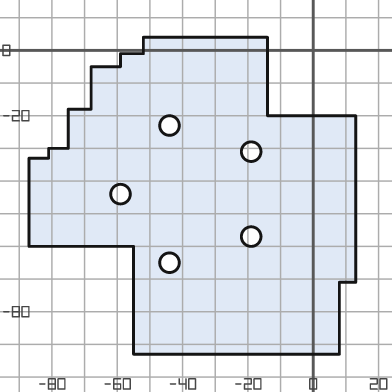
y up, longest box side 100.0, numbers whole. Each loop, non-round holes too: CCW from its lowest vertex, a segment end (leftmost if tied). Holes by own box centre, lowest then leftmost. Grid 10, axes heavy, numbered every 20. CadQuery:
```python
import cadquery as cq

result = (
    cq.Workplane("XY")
    .moveTo(-55.0, -93.0)
    .lineTo(8.0, -93.0)
    .lineTo(8.0, -71.0)
    .lineTo(13.0, -71.0)
    .lineTo(13.0, -20.0)
    .lineTo(-14.0, -20.0)
    .lineTo(-14.0, 4.0)
    .lineTo(-52.0, 4.0)
    .lineTo(-52.0, -1.0)
    .lineTo(-59.0, -1.0)
    .lineTo(-59.0, -5.0)
    .lineTo(-68.0, -5.0)
    .lineTo(-68.0, -18.0)
    .lineTo(-75.0, -18.0)
    .lineTo(-75.0, -30.0)
    .lineTo(-81.0, -30.0)
    .lineTo(-81.0, -33.0)
    .lineTo(-87.0, -33.0)
    .lineTo(-87.0, -60.0)
    .lineTo(-55.0, -60.0)
    .close()
    .moveTo(-44.0, -65.0)
    .circle(3.0)
    .moveTo(-19.0, -57.0)
    .circle(3.0)
    .moveTo(-59.0, -44.0)
    .circle(3.0)
    .moveTo(-19.0, -31.0)
    .circle(3.0)
    .moveTo(-44.0, -23.0)
    .circle(3.0)
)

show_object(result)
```